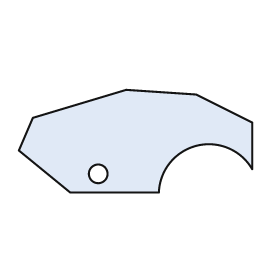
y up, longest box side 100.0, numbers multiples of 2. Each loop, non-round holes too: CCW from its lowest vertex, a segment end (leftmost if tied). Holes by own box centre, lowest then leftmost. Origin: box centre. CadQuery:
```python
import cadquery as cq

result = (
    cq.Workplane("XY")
    .moveTo(-28.0, -22.0)
    .lineTo(10.0, -22.0)
    .threePointArc((26.0, -2.0), (50.0, -12.0))
    .lineTo(50.0, 8.0)
    .lineTo(26.0, 20.0)
    .lineTo(-4.0, 22.0)
    .lineTo(-44.0, 10.0)
    .lineTo(-50.0, -4.0)
    .close()
    .moveTo(-16.0, -14.0)
    .circle(4.0)
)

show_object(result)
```